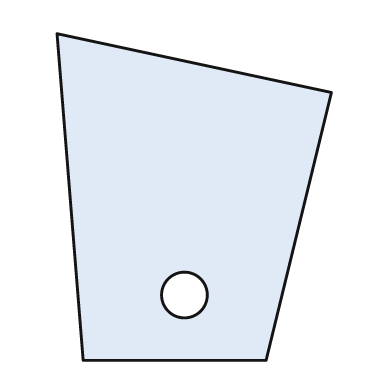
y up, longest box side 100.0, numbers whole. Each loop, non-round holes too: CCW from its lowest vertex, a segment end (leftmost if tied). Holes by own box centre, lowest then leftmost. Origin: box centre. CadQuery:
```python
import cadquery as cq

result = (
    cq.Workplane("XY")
    .moveTo(-34.0, -50.0)
    .lineTo(22.0, -50.0)
    .lineTo(42.0, 32.0)
    .lineTo(-42.0, 50.0)
    .close()
    .moveTo(-3.0, -30.0)
    .circle(7.0)
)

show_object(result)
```